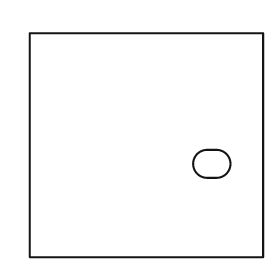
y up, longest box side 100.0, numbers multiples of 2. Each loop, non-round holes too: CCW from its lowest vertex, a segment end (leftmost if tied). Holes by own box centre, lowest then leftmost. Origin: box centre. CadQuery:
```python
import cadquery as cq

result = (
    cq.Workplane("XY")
    .moveTo(-50.0, -48.0)
    .lineTo(50.0, -48.0)
    .lineTo(50.0, 48.0)
    .lineTo(-50.0, 48.0)
    .close()
    .moveTo(26.0, -14.0)
    .lineTo(30.0, -14.0)
    .threePointArc((36.0, -8.0), (30.0, -2.0))
    .lineTo(26.0, -2.0)
    .threePointArc((20.0, -8.0), (26.0, -14.0))
    .close()
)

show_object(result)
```